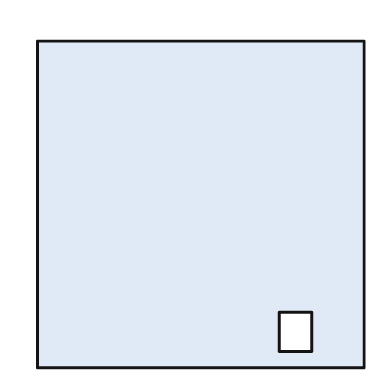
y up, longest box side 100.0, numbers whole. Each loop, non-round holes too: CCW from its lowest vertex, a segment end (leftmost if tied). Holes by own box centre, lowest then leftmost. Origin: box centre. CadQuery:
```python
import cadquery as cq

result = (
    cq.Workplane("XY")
    .moveTo(-50.0, -50.0)
    .lineTo(50.0, -50.0)
    .lineTo(50.0, 50.0)
    .lineTo(-50.0, 50.0)
    .close()
    .moveTo(24.0, -45.0)
    .lineTo(34.0, -45.0)
    .lineTo(34.0, -33.0)
    .lineTo(24.0, -33.0)
    .close()
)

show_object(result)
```